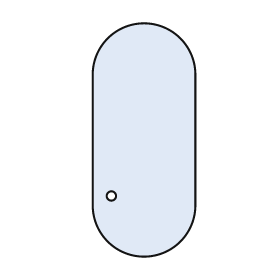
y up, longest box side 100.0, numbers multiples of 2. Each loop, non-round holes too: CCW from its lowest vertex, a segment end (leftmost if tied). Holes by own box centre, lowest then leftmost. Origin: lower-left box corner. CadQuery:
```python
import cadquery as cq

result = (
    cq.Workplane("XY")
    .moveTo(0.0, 22.0)
    .threePointArc((22.0, 0.0), (44.0, 22.0))
    .lineTo(44.0, 78.0)
    .threePointArc((22.0, 100.0), (0.0, 78.0))
    .close()
    .moveTo(8.0, 26.0)
    .circle(2.0)
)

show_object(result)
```